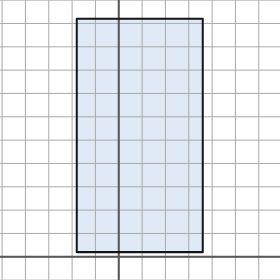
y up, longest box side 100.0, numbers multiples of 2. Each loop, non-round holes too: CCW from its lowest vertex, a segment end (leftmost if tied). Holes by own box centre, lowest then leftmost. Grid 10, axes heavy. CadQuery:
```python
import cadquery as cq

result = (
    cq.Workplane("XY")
    .moveTo(-18.0, 2.0)
    .lineTo(36.0, 2.0)
    .lineTo(36.0, 102.0)
    .lineTo(-18.0, 102.0)
    .close()
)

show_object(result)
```